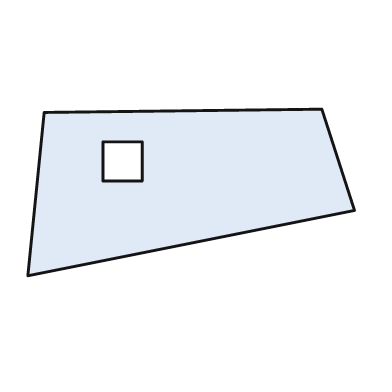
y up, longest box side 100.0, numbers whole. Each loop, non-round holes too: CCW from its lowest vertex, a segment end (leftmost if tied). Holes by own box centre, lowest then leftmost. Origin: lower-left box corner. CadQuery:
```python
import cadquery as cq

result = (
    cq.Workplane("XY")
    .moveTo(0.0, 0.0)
    .lineTo(100.0, 20.0)
    .lineTo(90.0, 51.0)
    .lineTo(5.0, 50.0)
    .close()
    .moveTo(23.0, 29.0)
    .lineTo(35.0, 29.0)
    .lineTo(35.0, 41.0)
    .lineTo(23.0, 41.0)
    .close()
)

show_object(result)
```